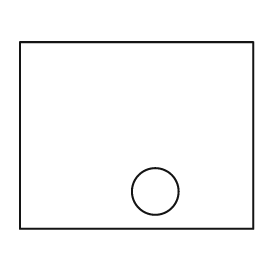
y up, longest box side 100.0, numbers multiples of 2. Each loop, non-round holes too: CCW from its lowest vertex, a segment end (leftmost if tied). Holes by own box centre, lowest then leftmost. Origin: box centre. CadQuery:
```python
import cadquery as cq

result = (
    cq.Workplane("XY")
    .moveTo(-50.0, -40.0)
    .lineTo(50.0, -40.0)
    .lineTo(50.0, 40.0)
    .lineTo(-50.0, 40.0)
    .close()
    .moveTo(8.0, -24.0)
    .circle(10.0)
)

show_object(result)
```